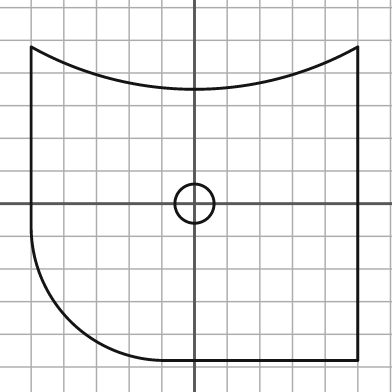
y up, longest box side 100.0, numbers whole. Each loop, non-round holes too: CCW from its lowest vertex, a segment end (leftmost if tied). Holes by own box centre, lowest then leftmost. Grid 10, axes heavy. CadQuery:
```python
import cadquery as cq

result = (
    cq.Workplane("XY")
    .moveTo(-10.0, -48.0)
    .lineTo(50.0, -48.0)
    .lineTo(50.0, 48.0)
    .threePointArc((0.0, 35.0), (-50.0, 48.0))
    .lineTo(-50.0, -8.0)
    .threePointArc((-38.0, -36.0), (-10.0, -48.0))
    .close()
    .moveTo(0.0, 0.0)
    .circle(6.0)
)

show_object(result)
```